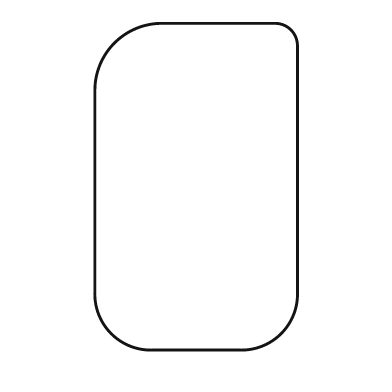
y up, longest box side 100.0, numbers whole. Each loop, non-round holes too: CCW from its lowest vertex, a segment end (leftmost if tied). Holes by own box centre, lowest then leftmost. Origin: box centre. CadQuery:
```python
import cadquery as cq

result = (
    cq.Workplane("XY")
    .moveTo(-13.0, -50.0)
    .lineTo(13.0, -50.0)
    .threePointArc((26.0, -45.0), (31.0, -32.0))
    .lineTo(31.0, 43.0)
    .threePointArc((29.0, 48.0), (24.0, 50.0))
    .lineTo(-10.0, 50.0)
    .threePointArc((-25.0, 44.0), (-31.0, 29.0))
    .lineTo(-31.0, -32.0)
    .threePointArc((-26.0, -45.0), (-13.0, -50.0))
    .close()
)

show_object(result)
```